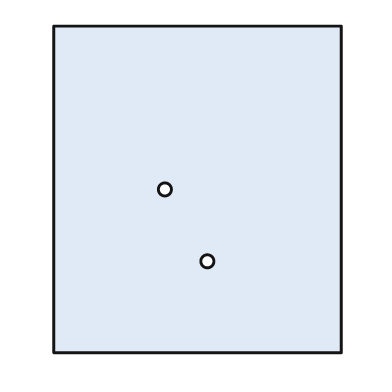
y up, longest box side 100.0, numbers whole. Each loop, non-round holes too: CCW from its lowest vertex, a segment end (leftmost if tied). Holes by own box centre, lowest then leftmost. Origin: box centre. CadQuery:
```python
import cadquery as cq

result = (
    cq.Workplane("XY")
    .moveTo(-44.0, -50.0)
    .lineTo(44.0, -50.0)
    .lineTo(44.0, 50.0)
    .lineTo(-44.0, 50.0)
    .close()
    .moveTo(3.0, -22.0)
    .circle(2.0)
    .moveTo(-10.0, 0.0)
    .circle(2.0)
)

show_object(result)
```